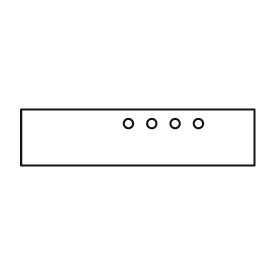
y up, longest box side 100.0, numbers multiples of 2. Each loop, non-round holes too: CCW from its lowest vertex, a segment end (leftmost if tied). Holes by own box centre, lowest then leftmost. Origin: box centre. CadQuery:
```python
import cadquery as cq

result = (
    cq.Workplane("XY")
    .moveTo(-50.0, -12.0)
    .lineTo(50.0, -12.0)
    .lineTo(50.0, 12.0)
    .lineTo(-50.0, 12.0)
    .close()
    .moveTo(-4.0, 6.0)
    .circle(2.0)
    .moveTo(6.0, 6.0)
    .circle(2.0)
    .moveTo(16.0, 6.0)
    .circle(2.0)
    .moveTo(26.0, 6.0)
    .circle(2.0)
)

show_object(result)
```